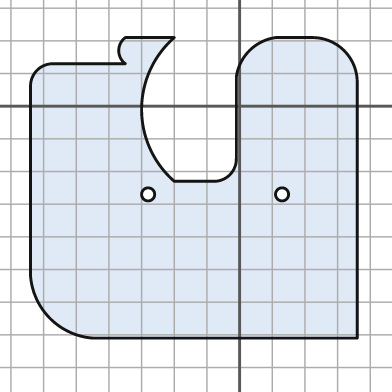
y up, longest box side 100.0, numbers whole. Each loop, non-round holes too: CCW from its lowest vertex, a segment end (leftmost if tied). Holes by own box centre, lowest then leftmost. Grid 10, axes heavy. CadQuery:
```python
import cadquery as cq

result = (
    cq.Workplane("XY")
    .moveTo(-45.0, -71.0)
    .lineTo(36.0, -71.0)
    .lineTo(36.0, 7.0)
    .threePointArc((32.0, 17.0), (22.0, 21.0))
    .lineTo(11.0, 21.0)
    .threePointArc((3.0, 17.0), (-1.0, 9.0))
    .lineTo(-1.0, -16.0)
    .threePointArc((-3.0, -21.0), (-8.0, -23.0))
    .lineTo(-20.0, -23.0)
    .threePointArc((-30.0, -1.0), (-20.0, 21.0))
    .lineTo(-35.0, 21.0)
    .threePointArc((-37.0, 17.0), (-35.0, 13.0))
    .lineTo(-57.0, 13.0)
    .threePointArc((-62.0, 11.0), (-64.0, 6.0))
    .lineTo(-64.0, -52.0)
    .threePointArc((-58.0, -65.0), (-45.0, -71.0))
    .close()
    .moveTo(-28.0, -27.0)
    .circle(2.0)
    .moveTo(13.0, -27.0)
    .circle(2.0)
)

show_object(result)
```